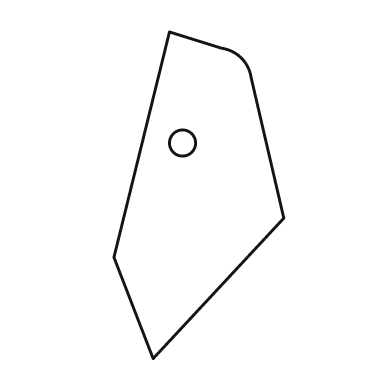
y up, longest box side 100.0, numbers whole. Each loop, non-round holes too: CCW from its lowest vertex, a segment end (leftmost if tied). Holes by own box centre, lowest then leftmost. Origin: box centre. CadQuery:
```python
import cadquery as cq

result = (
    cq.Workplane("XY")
    .moveTo(-14.0, -50.0)
    .lineTo(26.0, -7.0)
    .lineTo(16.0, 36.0)
    .threePointArc((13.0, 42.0), (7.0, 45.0))
    .lineTo(-9.0, 50.0)
    .lineTo(-26.0, -19.0)
    .close()
    .moveTo(-5.0, 16.0)
    .circle(4.0)
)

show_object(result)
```